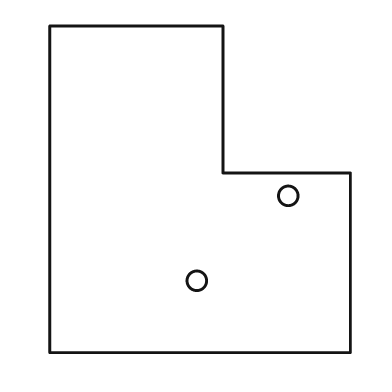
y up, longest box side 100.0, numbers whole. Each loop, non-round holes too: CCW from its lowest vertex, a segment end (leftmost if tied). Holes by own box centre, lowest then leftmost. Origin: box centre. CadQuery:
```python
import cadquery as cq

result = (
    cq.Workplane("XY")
    .moveTo(-46.0, -50.0)
    .lineTo(46.0, -50.0)
    .lineTo(46.0, 5.0)
    .lineTo(7.0, 5.0)
    .lineTo(7.0, 50.0)
    .lineTo(-46.0, 50.0)
    .close()
    .moveTo(-1.0, -28.0)
    .circle(3.0)
    .moveTo(27.0, -2.0)
    .circle(3.0)
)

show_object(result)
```